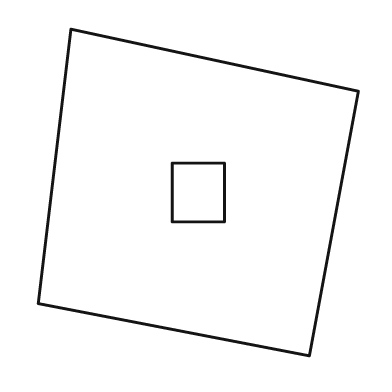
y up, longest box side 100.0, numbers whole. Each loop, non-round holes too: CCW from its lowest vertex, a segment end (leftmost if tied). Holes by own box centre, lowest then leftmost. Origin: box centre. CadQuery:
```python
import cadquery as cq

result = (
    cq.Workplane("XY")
    .moveTo(34.0, -50.0)
    .lineTo(49.0, 31.0)
    .lineTo(-39.0, 50.0)
    .lineTo(-49.0, -34.0)
    .close()
    .moveTo(-8.0, -9.0)
    .lineTo(8.0, -9.0)
    .lineTo(8.0, 9.0)
    .lineTo(-8.0, 9.0)
    .close()
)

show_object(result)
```